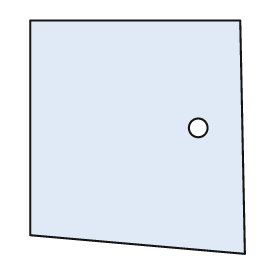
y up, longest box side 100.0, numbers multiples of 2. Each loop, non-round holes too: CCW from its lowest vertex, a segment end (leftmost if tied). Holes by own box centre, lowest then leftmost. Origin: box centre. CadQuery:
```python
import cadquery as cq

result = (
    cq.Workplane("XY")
    .moveTo(46.0, -50.0)
    .lineTo(44.0, 50.0)
    .lineTo(-46.0, 50.0)
    .lineTo(-46.0, -42.0)
    .close()
    .moveTo(26.0, 4.0)
    .circle(4.0)
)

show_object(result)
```